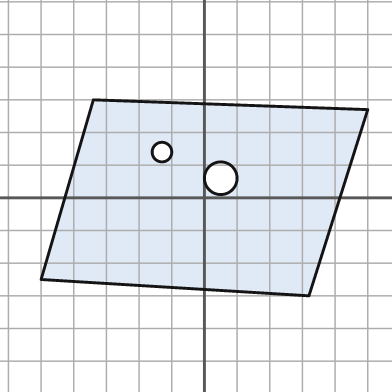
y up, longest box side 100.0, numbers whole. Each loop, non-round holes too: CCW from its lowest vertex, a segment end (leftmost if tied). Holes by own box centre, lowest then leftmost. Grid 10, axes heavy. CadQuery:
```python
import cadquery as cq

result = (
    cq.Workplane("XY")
    .moveTo(32.0, -30.0)
    .lineTo(50.0, 27.0)
    .lineTo(-34.0, 30.0)
    .lineTo(-50.0, -25.0)
    .close()
    .moveTo(5.0, 6.0)
    .circle(5.0)
    .moveTo(-13.0, 14.0)
    .circle(3.0)
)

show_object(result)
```